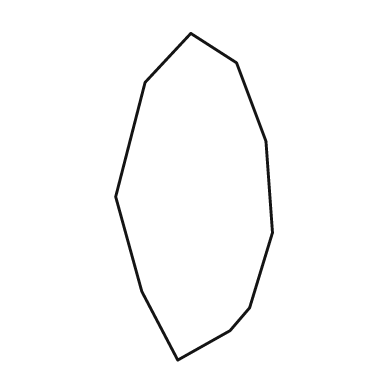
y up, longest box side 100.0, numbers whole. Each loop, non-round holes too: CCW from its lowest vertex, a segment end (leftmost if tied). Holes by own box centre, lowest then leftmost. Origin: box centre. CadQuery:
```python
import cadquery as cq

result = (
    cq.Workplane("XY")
    .moveTo(-5.0, -50.0)
    .lineTo(11.0, -41.0)
    .lineTo(17.0, -34.0)
    .lineTo(24.0, -11.0)
    .lineTo(22.0, 17.0)
    .lineTo(13.0, 41.0)
    .lineTo(-1.0, 50.0)
    .lineTo(-15.0, 35.0)
    .lineTo(-24.0, 0.0)
    .lineTo(-16.0, -29.0)
    .close()
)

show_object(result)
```